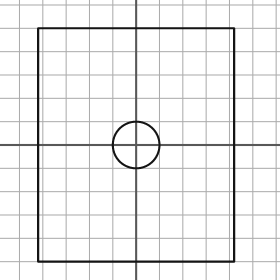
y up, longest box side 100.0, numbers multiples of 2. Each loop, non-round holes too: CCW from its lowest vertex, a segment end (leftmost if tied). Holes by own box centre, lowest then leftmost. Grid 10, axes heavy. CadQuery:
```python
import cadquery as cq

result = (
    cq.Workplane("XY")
    .moveTo(-42.0, -50.0)
    .lineTo(42.0, -50.0)
    .lineTo(42.0, 50.0)
    .lineTo(-42.0, 50.0)
    .close()
    .moveTo(0.0, 0.0)
    .circle(10.0)
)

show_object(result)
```